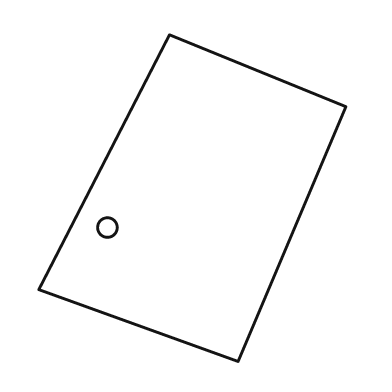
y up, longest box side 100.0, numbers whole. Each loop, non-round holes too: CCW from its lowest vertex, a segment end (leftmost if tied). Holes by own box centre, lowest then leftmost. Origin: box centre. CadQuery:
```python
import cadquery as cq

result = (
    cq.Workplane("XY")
    .moveTo(14.0, -50.0)
    .lineTo(47.0, 28.0)
    .lineTo(-7.0, 50.0)
    .lineTo(-47.0, -28.0)
    .close()
    .moveTo(-26.0, -9.0)
    .circle(3.0)
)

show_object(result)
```